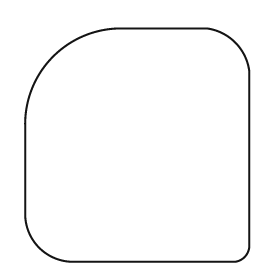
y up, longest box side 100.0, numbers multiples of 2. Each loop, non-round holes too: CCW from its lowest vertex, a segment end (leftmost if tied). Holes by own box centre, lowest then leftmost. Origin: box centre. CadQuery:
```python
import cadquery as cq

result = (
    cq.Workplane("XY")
    .moveTo(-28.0, -50.0)
    .lineTo(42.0, -50.0)
    .threePointArc((46.0, -48.0), (48.0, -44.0))
    .lineTo(48.0, 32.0)
    .threePointArc((42.0, 44.0), (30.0, 50.0))
    .lineTo(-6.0, 50.0)
    .threePointArc((-36.0, 38.0), (-48.0, 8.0))
    .lineTo(-48.0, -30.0)
    .threePointArc((-42.0, -44.0), (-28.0, -50.0))
    .close()
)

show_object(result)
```